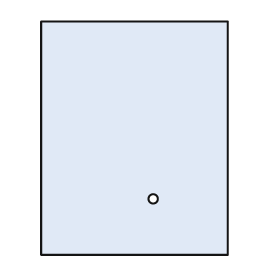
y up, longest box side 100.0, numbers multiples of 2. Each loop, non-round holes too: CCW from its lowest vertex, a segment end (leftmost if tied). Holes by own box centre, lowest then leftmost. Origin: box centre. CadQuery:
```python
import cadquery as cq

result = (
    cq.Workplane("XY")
    .moveTo(-40.0, -50.0)
    .lineTo(40.0, -50.0)
    .lineTo(40.0, 50.0)
    .lineTo(-40.0, 50.0)
    .close()
    .moveTo(8.0, -26.0)
    .circle(2.0)
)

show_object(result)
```